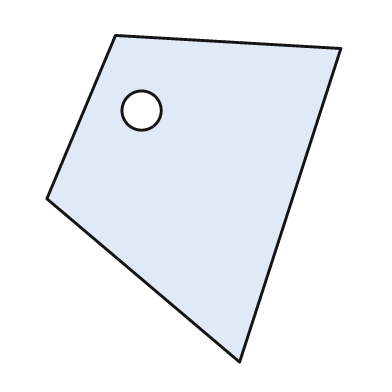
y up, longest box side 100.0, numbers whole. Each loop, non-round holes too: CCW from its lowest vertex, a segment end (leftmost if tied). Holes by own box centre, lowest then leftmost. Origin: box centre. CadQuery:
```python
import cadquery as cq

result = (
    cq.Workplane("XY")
    .moveTo(14.0, -50.0)
    .lineTo(45.0, 46.0)
    .lineTo(-24.0, 50.0)
    .lineTo(-45.0, 0.0)
    .close()
    .moveTo(-16.0, 27.0)
    .circle(6.0)
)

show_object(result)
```